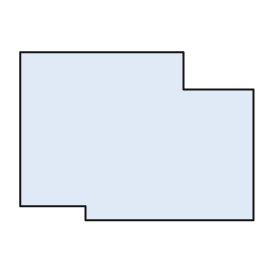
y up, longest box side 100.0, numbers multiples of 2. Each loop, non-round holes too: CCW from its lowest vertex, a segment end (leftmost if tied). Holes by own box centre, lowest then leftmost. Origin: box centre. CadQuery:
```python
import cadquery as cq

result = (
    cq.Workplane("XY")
    .moveTo(-22.0, -36.0)
    .lineTo(50.0, -36.0)
    .lineTo(50.0, 20.0)
    .lineTo(20.0, 20.0)
    .lineTo(20.0, 36.0)
    .lineTo(-50.0, 36.0)
    .lineTo(-50.0, -30.0)
    .lineTo(-22.0, -30.0)
    .close()
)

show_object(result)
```